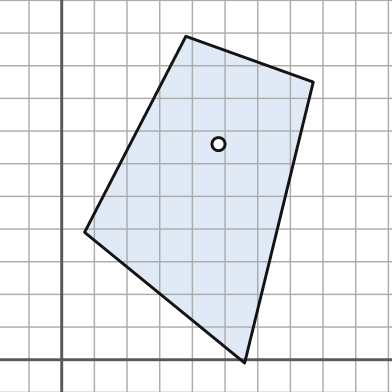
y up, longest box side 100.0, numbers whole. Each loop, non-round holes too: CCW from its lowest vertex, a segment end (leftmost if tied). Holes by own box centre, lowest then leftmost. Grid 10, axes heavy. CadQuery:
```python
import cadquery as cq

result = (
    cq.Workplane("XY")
    .moveTo(56.0, -1.0)
    .lineTo(77.0, 85.0)
    .lineTo(38.0, 99.0)
    .lineTo(7.0, 39.0)
    .close()
    .moveTo(48.0, 66.0)
    .circle(2.0)
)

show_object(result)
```